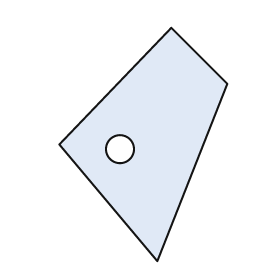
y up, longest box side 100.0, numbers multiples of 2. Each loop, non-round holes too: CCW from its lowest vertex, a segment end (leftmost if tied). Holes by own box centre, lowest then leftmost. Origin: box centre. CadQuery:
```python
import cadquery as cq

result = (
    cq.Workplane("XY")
    .moveTo(6.0, -50.0)
    .lineTo(36.0, 26.0)
    .lineTo(12.0, 50.0)
    .lineTo(-36.0, 0.0)
    .close()
    .moveTo(-10.0, -2.0)
    .circle(6.0)
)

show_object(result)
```